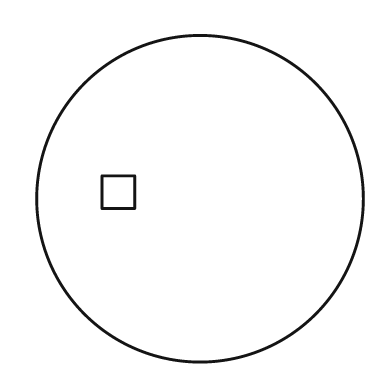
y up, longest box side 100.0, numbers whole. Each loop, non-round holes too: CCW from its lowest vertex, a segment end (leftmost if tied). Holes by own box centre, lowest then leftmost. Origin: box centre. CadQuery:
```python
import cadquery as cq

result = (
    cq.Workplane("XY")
    .moveTo(0.0, 0.0)
    .circle(50.0)
    .moveTo(-30.0, -3.0)
    .lineTo(-20.0, -3.0)
    .lineTo(-20.0, 7.0)
    .lineTo(-30.0, 7.0)
    .close()
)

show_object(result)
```